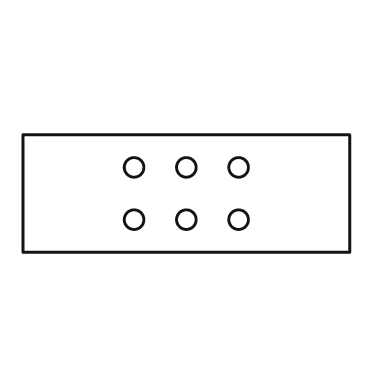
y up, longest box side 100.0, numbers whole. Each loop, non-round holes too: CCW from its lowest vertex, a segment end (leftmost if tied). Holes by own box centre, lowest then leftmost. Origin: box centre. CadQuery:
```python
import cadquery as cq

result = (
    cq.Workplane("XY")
    .moveTo(-50.0, -18.0)
    .lineTo(50.0, -18.0)
    .lineTo(50.0, 18.0)
    .lineTo(-50.0, 18.0)
    .close()
    .moveTo(-16.0, -8.0)
    .circle(3.0)
    .moveTo(0.0, -8.0)
    .circle(3.0)
    .moveTo(16.0, -8.0)
    .circle(3.0)
    .moveTo(-16.0, 8.0)
    .circle(3.0)
    .moveTo(0.0, 8.0)
    .circle(3.0)
    .moveTo(16.0, 8.0)
    .circle(3.0)
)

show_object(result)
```